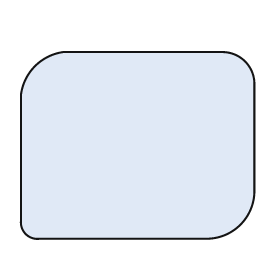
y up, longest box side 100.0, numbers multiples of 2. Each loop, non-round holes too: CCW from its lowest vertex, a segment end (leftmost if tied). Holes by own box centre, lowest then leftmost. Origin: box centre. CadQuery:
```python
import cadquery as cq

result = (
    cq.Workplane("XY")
    .moveTo(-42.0, -40.0)
    .lineTo(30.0, -40.0)
    .threePointArc((44.0, -34.0), (50.0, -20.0))
    .lineTo(50.0, 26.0)
    .threePointArc((46.0, 36.0), (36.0, 40.0))
    .lineTo(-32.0, 40.0)
    .threePointArc((-44.0, 34.0), (-50.0, 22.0))
    .lineTo(-50.0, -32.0)
    .threePointArc((-48.0, -38.0), (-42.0, -40.0))
    .close()
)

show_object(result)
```